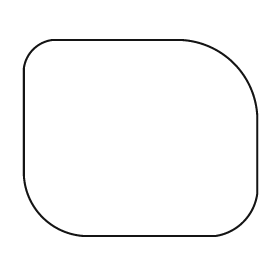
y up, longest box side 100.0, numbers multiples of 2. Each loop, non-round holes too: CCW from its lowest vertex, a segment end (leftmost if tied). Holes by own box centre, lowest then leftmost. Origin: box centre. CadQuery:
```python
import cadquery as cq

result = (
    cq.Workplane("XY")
    .moveTo(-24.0, -42.0)
    .lineTo(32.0, -42.0)
    .threePointArc((44.0, -36.0), (50.0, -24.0))
    .lineTo(50.0, 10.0)
    .threePointArc((40.0, 32.0), (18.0, 42.0))
    .lineTo(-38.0, 42.0)
    .threePointArc((-46.0, 38.0), (-50.0, 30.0))
    .lineTo(-50.0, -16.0)
    .threePointArc((-42.0, -34.0), (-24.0, -42.0))
    .close()
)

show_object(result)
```